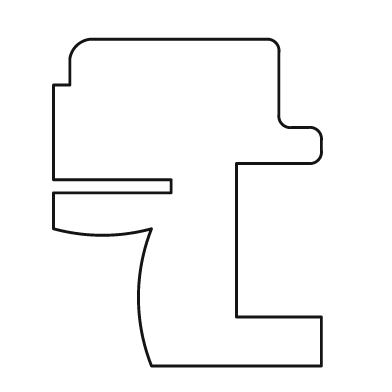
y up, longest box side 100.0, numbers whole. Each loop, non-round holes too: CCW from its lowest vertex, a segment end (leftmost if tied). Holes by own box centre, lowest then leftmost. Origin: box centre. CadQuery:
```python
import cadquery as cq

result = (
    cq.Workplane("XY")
    .moveTo(-11.0, -50.0)
    .lineTo(41.0, -50.0)
    .lineTo(41.0, -35.0)
    .lineTo(15.0, -35.0)
    .lineTo(15.0, 12.0)
    .lineTo(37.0, 12.0)
    .threePointArc((40.0, 13.0), (41.0, 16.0))
    .lineTo(41.0, 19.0)
    .threePointArc((40.0, 22.0), (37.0, 23.0))
    .lineTo(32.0, 23.0)
    .threePointArc((29.0, 24.0), (28.0, 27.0))
    .lineTo(28.0, 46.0)
    .threePointArc((27.0, 49.0), (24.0, 50.0))
    .lineTo(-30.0, 50.0)
    .threePointArc((-34.0, 48.0), (-36.0, 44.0))
    .lineTo(-36.0, 36.0)
    .lineTo(-41.0, 36.0)
    .lineTo(-41.0, 7.0)
    .lineTo(-5.0, 7.0)
    .lineTo(-5.0, 3.0)
    .lineTo(-41.0, 3.0)
    .lineTo(-41.0, -8.0)
    .threePointArc((-26.0, -10.0), (-11.0, -8.0))
    .threePointArc((-15.0, -29.0), (-11.0, -50.0))
    .close()
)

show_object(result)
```